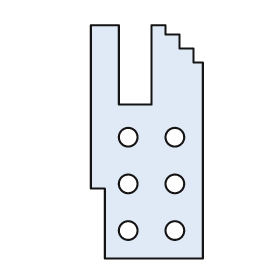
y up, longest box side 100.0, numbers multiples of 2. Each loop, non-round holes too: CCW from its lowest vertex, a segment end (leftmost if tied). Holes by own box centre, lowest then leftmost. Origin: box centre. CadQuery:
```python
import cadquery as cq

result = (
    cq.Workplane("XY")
    .moveTo(-18.0, -50.0)
    .lineTo(24.0, -50.0)
    .lineTo(24.0, 34.0)
    .lineTo(20.0, 34.0)
    .lineTo(20.0, 40.0)
    .lineTo(14.0, 40.0)
    .lineTo(14.0, 46.0)
    .lineTo(8.0, 46.0)
    .lineTo(8.0, 50.0)
    .lineTo(2.0, 50.0)
    .lineTo(2.0, 16.0)
    .lineTo(-12.0, 16.0)
    .lineTo(-12.0, 50.0)
    .lineTo(-24.0, 50.0)
    .lineTo(-24.0, -20.0)
    .lineTo(-18.0, -20.0)
    .close()
    .moveTo(-8.0, -38.0)
    .circle(4.0)
    .moveTo(12.0, -38.0)
    .circle(4.0)
    .moveTo(-8.0, -18.0)
    .circle(4.0)
    .moveTo(12.0, -18.0)
    .circle(4.0)
    .moveTo(-8.0, 2.0)
    .circle(4.0)
    .moveTo(12.0, 2.0)
    .circle(4.0)
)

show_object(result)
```